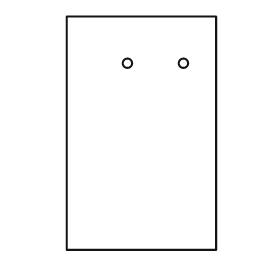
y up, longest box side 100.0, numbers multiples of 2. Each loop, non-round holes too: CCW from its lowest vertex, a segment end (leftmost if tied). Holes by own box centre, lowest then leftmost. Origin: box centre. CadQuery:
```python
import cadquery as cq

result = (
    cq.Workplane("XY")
    .moveTo(-32.0, -50.0)
    .lineTo(32.0, -50.0)
    .lineTo(32.0, 50.0)
    .lineTo(-32.0, 50.0)
    .close()
    .moveTo(-6.0, 30.0)
    .circle(2.0)
    .moveTo(18.0, 30.0)
    .circle(2.0)
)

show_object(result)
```